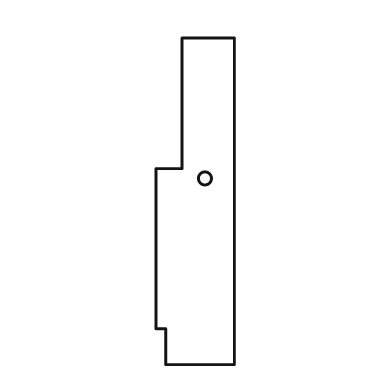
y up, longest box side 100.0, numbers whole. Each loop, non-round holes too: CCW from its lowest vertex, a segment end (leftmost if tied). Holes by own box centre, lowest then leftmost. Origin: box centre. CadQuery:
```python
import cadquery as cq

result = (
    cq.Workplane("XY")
    .moveTo(-9.0, -50.0)
    .lineTo(12.0, -50.0)
    .lineTo(12.0, 50.0)
    .lineTo(-4.0, 50.0)
    .lineTo(-4.0, 10.0)
    .lineTo(-12.0, 10.0)
    .lineTo(-12.0, -39.0)
    .lineTo(-9.0, -39.0)
    .close()
    .moveTo(3.0, 7.0)
    .circle(2.0)
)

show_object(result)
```